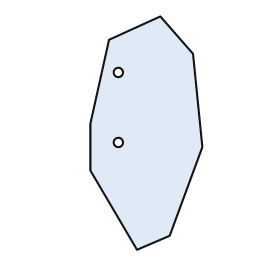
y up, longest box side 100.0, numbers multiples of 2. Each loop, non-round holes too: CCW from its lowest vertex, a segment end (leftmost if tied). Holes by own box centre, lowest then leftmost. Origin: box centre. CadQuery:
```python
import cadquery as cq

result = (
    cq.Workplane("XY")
    .moveTo(-4.0, -50.0)
    .lineTo(10.0, -44.0)
    .lineTo(24.0, -6.0)
    .lineTo(20.0, 34.0)
    .lineTo(6.0, 50.0)
    .lineTo(-16.0, 40.0)
    .lineTo(-24.0, 4.0)
    .lineTo(-24.0, -16.0)
    .close()
    .moveTo(-12.0, -4.0)
    .circle(2.0)
    .moveTo(-12.0, 26.0)
    .circle(2.0)
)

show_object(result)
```